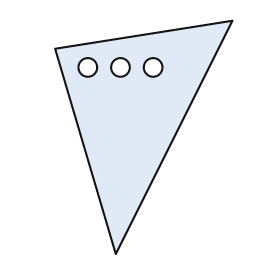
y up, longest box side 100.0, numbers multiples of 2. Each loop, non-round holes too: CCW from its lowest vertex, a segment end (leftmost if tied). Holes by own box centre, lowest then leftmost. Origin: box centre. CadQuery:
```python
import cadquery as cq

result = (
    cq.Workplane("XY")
    .moveTo(-12.0, -50.0)
    .lineTo(38.0, 50.0)
    .lineTo(-38.0, 38.0)
    .close()
    .moveTo(-24.0, 30.0)
    .circle(4.0)
    .moveTo(-10.0, 30.0)
    .circle(4.0)
    .moveTo(4.0, 30.0)
    .circle(4.0)
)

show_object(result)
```